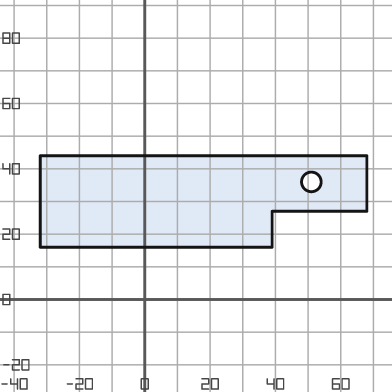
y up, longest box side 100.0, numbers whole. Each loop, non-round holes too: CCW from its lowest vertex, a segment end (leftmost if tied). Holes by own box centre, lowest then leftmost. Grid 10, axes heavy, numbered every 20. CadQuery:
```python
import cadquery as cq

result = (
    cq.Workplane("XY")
    .moveTo(-32.0, 16.0)
    .lineTo(39.0, 16.0)
    .lineTo(39.0, 27.0)
    .lineTo(68.0, 27.0)
    .lineTo(68.0, 44.0)
    .lineTo(-32.0, 44.0)
    .close()
    .moveTo(51.0, 36.0)
    .circle(3.0)
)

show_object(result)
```